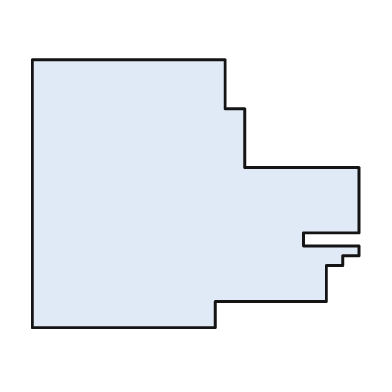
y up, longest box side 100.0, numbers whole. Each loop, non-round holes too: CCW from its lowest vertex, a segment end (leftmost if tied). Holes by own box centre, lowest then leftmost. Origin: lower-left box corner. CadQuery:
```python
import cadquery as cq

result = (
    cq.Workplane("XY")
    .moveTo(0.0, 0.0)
    .lineTo(56.0, 0.0)
    .lineTo(56.0, 8.0)
    .lineTo(90.0, 8.0)
    .lineTo(90.0, 19.0)
    .lineTo(95.0, 19.0)
    .lineTo(95.0, 22.0)
    .lineTo(100.0, 22.0)
    .lineTo(100.0, 25.0)
    .lineTo(83.0, 25.0)
    .lineTo(83.0, 29.0)
    .lineTo(100.0, 29.0)
    .lineTo(100.0, 49.0)
    .lineTo(65.0, 49.0)
    .lineTo(65.0, 67.0)
    .lineTo(59.0, 67.0)
    .lineTo(59.0, 82.0)
    .lineTo(0.0, 82.0)
    .close()
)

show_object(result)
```